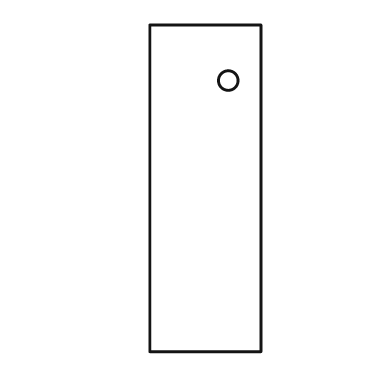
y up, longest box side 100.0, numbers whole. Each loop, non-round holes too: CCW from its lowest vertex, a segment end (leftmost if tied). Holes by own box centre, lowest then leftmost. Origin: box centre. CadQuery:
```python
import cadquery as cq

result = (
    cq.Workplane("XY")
    .moveTo(-17.0, -50.0)
    .lineTo(17.0, -50.0)
    .lineTo(17.0, 50.0)
    .lineTo(-17.0, 50.0)
    .close()
    .moveTo(7.0, 33.0)
    .circle(3.0)
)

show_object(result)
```